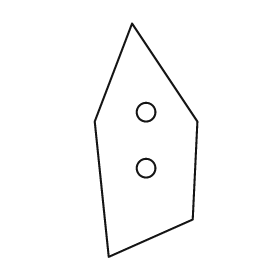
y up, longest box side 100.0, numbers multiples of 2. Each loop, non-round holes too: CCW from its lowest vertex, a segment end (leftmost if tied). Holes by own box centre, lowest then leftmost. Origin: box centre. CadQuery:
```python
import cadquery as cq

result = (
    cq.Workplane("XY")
    .moveTo(-16.0, -50.0)
    .lineTo(20.0, -34.0)
    .lineTo(22.0, 8.0)
    .lineTo(-6.0, 50.0)
    .lineTo(-22.0, 8.0)
    .close()
    .moveTo(0.0, -12.0)
    .circle(4.0)
    .moveTo(0.0, 12.0)
    .circle(4.0)
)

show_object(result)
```